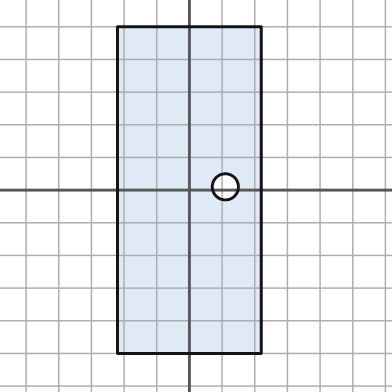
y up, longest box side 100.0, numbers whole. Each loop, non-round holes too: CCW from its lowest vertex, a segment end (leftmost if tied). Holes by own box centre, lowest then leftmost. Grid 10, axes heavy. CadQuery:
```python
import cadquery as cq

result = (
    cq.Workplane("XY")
    .moveTo(-22.0, -50.0)
    .lineTo(22.0, -50.0)
    .lineTo(22.0, 50.0)
    .lineTo(-22.0, 50.0)
    .close()
    .moveTo(11.0, 1.0)
    .circle(4.0)
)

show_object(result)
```